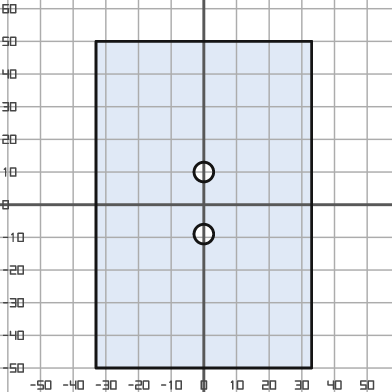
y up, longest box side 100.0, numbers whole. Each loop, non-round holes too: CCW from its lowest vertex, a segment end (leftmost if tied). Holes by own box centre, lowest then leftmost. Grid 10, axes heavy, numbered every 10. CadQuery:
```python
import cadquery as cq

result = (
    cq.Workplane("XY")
    .moveTo(-33.0, -50.0)
    .lineTo(33.0, -50.0)
    .lineTo(33.0, 50.0)
    .lineTo(-33.0, 50.0)
    .close()
    .moveTo(0.0, -9.0)
    .circle(3.0)
    .moveTo(0.0, 10.0)
    .circle(3.0)
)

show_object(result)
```